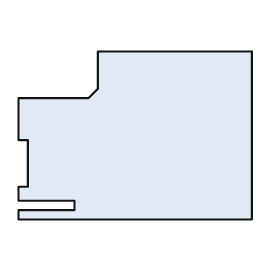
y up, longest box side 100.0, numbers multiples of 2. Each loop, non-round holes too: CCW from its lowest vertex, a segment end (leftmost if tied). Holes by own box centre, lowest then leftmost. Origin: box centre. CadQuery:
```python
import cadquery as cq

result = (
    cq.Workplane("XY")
    .moveTo(-50.0, -36.0)
    .lineTo(50.0, -36.0)
    .lineTo(50.0, 36.0)
    .lineTo(-16.0, 36.0)
    .lineTo(-16.0, 20.0)
    .lineTo(-20.0, 16.0)
    .lineTo(-50.0, 16.0)
    .lineTo(-50.0, -2.0)
    .lineTo(-46.0, -2.0)
    .lineTo(-46.0, -22.0)
    .lineTo(-50.0, -22.0)
    .lineTo(-50.0, -28.0)
    .lineTo(-26.0, -28.0)
    .lineTo(-26.0, -32.0)
    .lineTo(-50.0, -32.0)
    .close()
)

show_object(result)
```